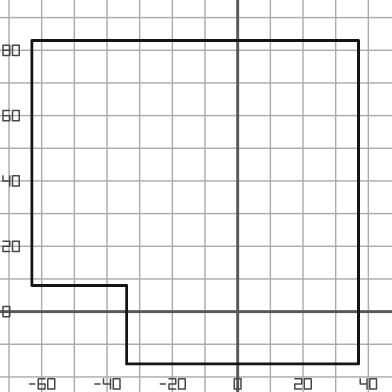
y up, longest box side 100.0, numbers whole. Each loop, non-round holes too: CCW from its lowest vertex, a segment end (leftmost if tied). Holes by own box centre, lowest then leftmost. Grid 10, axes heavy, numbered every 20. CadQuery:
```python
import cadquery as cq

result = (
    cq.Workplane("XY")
    .moveTo(-34.0, -16.0)
    .lineTo(37.0, -16.0)
    .lineTo(37.0, 83.0)
    .lineTo(-63.0, 83.0)
    .lineTo(-63.0, 8.0)
    .lineTo(-34.0, 8.0)
    .close()
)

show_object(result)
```